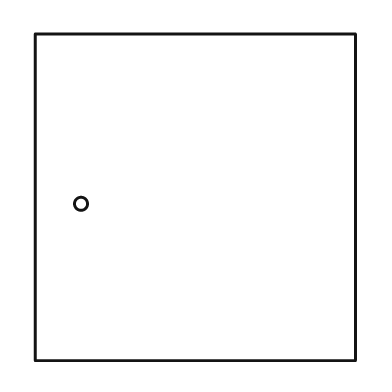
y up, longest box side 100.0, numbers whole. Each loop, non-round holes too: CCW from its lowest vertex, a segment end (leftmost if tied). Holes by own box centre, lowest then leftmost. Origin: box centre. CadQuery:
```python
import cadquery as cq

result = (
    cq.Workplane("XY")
    .moveTo(-49.0, -50.0)
    .lineTo(49.0, -50.0)
    .lineTo(49.0, 50.0)
    .lineTo(-49.0, 50.0)
    .close()
    .moveTo(-35.0, -2.0)
    .circle(2.0)
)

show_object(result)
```